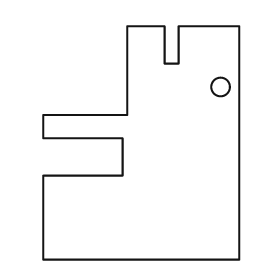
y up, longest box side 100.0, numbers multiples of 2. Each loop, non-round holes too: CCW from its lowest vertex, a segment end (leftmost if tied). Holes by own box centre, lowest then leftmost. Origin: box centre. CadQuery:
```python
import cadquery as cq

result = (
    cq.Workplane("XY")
    .moveTo(-42.0, -50.0)
    .lineTo(42.0, -50.0)
    .lineTo(42.0, 50.0)
    .lineTo(16.0, 50.0)
    .lineTo(16.0, 34.0)
    .lineTo(10.0, 34.0)
    .lineTo(10.0, 50.0)
    .lineTo(-6.0, 50.0)
    .lineTo(-6.0, 12.0)
    .lineTo(-42.0, 12.0)
    .lineTo(-42.0, 2.0)
    .lineTo(-8.0, 2.0)
    .lineTo(-8.0, -14.0)
    .lineTo(-42.0, -14.0)
    .close()
    .moveTo(34.0, 24.0)
    .circle(4.0)
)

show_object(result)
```